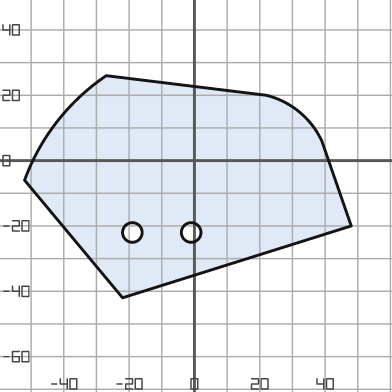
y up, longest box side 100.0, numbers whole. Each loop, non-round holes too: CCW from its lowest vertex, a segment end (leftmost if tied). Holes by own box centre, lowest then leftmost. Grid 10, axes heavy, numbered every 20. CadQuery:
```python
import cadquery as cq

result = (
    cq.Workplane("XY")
    .moveTo(-22.0, -42.0)
    .lineTo(48.0, -20.0)
    .lineTo(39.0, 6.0)
    .threePointArc((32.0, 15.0), (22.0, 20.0))
    .lineTo(-27.0, 26.0)
    .threePointArc((-42.0, 12.0), (-52.0, -6.0))
    .close()
    .moveTo(-19.0, -22.0)
    .circle(3.0)
    .moveTo(-1.0, -22.0)
    .circle(3.0)
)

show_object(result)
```